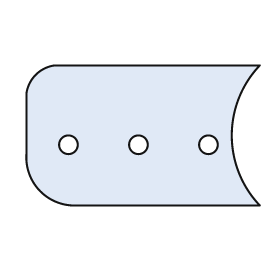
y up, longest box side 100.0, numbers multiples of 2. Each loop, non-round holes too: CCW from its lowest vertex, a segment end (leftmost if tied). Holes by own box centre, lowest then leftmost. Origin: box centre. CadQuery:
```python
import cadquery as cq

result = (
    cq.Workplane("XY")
    .moveTo(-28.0, -30.0)
    .lineTo(50.0, -30.0)
    .threePointArc((38.0, 0.0), (50.0, 30.0))
    .lineTo(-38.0, 30.0)
    .threePointArc((-46.0, 26.0), (-50.0, 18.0))
    .lineTo(-50.0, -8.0)
    .threePointArc((-44.0, -24.0), (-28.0, -30.0))
    .close()
    .moveTo(-32.0, -4.0)
    .circle(4.0)
    .moveTo(-2.0, -4.0)
    .circle(4.0)
    .moveTo(28.0, -4.0)
    .circle(4.0)
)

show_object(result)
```